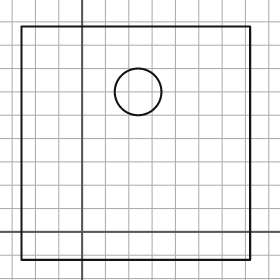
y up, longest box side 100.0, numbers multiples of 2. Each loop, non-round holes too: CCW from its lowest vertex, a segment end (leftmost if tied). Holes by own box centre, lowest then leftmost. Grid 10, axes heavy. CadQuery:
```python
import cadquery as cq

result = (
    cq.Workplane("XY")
    .moveTo(-26.0, -12.0)
    .lineTo(72.0, -12.0)
    .lineTo(72.0, 88.0)
    .lineTo(-26.0, 88.0)
    .close()
    .moveTo(24.0, 60.0)
    .circle(10.0)
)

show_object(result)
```